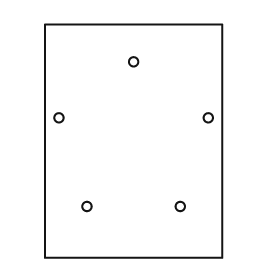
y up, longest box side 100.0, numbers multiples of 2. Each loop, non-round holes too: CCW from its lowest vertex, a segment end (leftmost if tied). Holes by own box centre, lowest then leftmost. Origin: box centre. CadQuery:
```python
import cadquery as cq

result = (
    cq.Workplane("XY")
    .moveTo(-38.0, -50.0)
    .lineTo(38.0, -50.0)
    .lineTo(38.0, 50.0)
    .lineTo(-38.0, 50.0)
    .close()
    .moveTo(-20.0, -28.0)
    .circle(2.0)
    .moveTo(20.0, -28.0)
    .circle(2.0)
    .moveTo(-32.0, 10.0)
    .circle(2.0)
    .moveTo(32.0, 10.0)
    .circle(2.0)
    .moveTo(0.0, 34.0)
    .circle(2.0)
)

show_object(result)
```